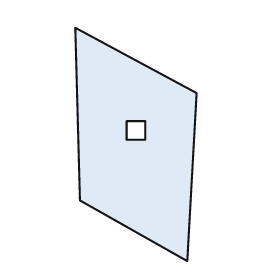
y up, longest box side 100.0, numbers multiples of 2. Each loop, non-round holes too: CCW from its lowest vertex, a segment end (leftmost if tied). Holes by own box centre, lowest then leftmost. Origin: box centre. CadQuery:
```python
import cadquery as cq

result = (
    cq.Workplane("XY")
    .moveTo(22.0, -50.0)
    .lineTo(26.0, 22.0)
    .lineTo(-26.0, 50.0)
    .lineTo(-24.0, -24.0)
    .close()
    .moveTo(-4.0, 2.0)
    .lineTo(4.0, 2.0)
    .lineTo(4.0, 10.0)
    .lineTo(-4.0, 10.0)
    .close()
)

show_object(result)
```